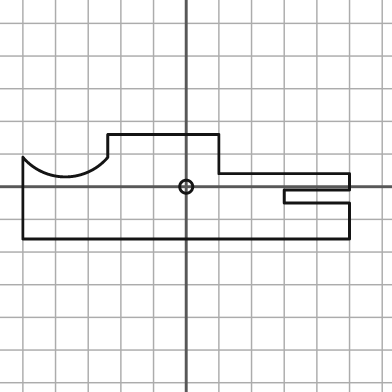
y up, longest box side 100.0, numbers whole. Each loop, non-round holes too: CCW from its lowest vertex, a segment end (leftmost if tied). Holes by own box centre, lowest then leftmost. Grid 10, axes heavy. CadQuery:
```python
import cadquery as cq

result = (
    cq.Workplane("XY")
    .moveTo(-50.0, -16.0)
    .lineTo(50.0, -16.0)
    .lineTo(50.0, -5.0)
    .lineTo(30.0, -5.0)
    .lineTo(30.0, -1.0)
    .lineTo(50.0, -1.0)
    .lineTo(50.0, 4.0)
    .lineTo(10.0, 4.0)
    .lineTo(10.0, 16.0)
    .lineTo(-24.0, 16.0)
    .lineTo(-24.0, 9.0)
    .threePointArc((-37.0, 3.0), (-50.0, 9.0))
    .close()
    .moveTo(0.0, 0.0)
    .circle(2.0)
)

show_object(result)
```